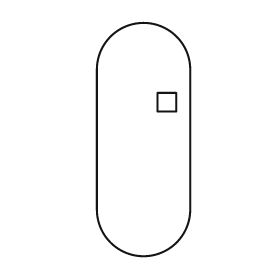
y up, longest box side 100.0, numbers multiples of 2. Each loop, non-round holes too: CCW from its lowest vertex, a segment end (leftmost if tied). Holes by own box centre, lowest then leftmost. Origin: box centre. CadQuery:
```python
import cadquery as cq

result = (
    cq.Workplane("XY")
    .moveTo(-20.0, -30.0)
    .threePointArc((0.0, -50.0), (20.0, -30.0))
    .lineTo(20.0, 30.0)
    .threePointArc((0.0, 50.0), (-20.0, 30.0))
    .close()
    .moveTo(6.0, 12.0)
    .lineTo(14.0, 12.0)
    .lineTo(14.0, 20.0)
    .lineTo(6.0, 20.0)
    .close()
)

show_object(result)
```